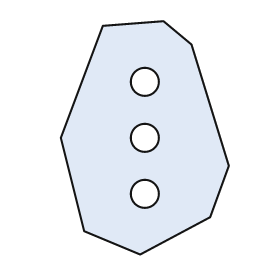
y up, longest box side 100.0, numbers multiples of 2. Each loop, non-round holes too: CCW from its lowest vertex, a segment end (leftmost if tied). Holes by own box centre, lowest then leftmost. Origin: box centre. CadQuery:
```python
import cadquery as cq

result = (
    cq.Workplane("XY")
    .moveTo(-2.0, -50.0)
    .lineTo(28.0, -34.0)
    .lineTo(36.0, -12.0)
    .lineTo(20.0, 40.0)
    .lineTo(8.0, 50.0)
    .lineTo(-18.0, 48.0)
    .lineTo(-36.0, 0.0)
    .lineTo(-26.0, -40.0)
    .close()
    .moveTo(0.0, -24.0)
    .circle(6.0)
    .moveTo(0.0, 0.0)
    .circle(6.0)
    .moveTo(0.0, 24.0)
    .circle(6.0)
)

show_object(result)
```